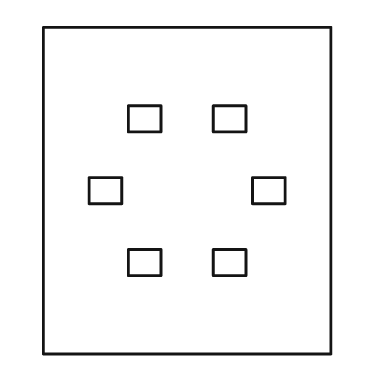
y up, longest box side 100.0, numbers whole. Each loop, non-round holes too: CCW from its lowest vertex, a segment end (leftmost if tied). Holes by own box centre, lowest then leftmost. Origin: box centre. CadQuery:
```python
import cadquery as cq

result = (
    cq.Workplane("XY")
    .moveTo(-44.0, -50.0)
    .lineTo(44.0, -50.0)
    .lineTo(44.0, 50.0)
    .lineTo(-44.0, 50.0)
    .close()
    .moveTo(-18.0, -26.0)
    .lineTo(-8.0, -26.0)
    .lineTo(-8.0, -18.0)
    .lineTo(-18.0, -18.0)
    .close()
    .moveTo(8.0, -26.0)
    .lineTo(18.0, -26.0)
    .lineTo(18.0, -18.0)
    .lineTo(8.0, -18.0)
    .close()
    .moveTo(-30.0, -4.0)
    .lineTo(-20.0, -4.0)
    .lineTo(-20.0, 4.0)
    .lineTo(-30.0, 4.0)
    .close()
    .moveTo(20.0, -4.0)
    .lineTo(30.0, -4.0)
    .lineTo(30.0, 4.0)
    .lineTo(20.0, 4.0)
    .close()
    .moveTo(-18.0, 18.0)
    .lineTo(-8.0, 18.0)
    .lineTo(-8.0, 26.0)
    .lineTo(-18.0, 26.0)
    .close()
    .moveTo(8.0, 18.0)
    .lineTo(18.0, 18.0)
    .lineTo(18.0, 26.0)
    .lineTo(8.0, 26.0)
    .close()
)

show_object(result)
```